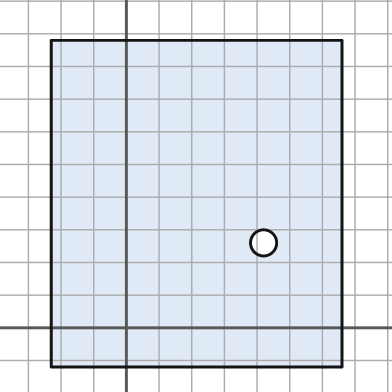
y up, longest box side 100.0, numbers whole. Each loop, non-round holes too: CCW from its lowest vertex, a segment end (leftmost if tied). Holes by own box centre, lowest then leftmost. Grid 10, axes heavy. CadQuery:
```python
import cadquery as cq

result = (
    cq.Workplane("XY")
    .moveTo(-23.0, -12.0)
    .lineTo(66.0, -12.0)
    .lineTo(66.0, 88.0)
    .lineTo(-23.0, 88.0)
    .close()
    .moveTo(42.0, 26.0)
    .circle(4.0)
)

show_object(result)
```